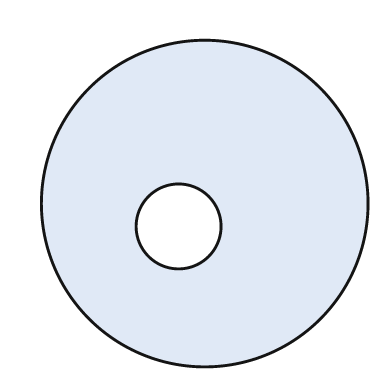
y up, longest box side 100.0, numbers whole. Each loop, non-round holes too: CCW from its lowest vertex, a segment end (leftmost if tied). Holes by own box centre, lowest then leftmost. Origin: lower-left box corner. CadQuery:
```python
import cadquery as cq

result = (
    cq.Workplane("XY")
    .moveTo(50.0, 50.0)
    .circle(50.0)
    .moveTo(42.0, 43.0)
    .circle(13.0)
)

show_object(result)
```